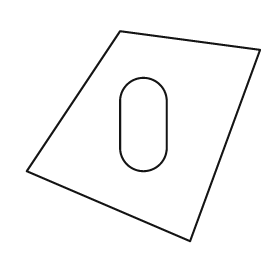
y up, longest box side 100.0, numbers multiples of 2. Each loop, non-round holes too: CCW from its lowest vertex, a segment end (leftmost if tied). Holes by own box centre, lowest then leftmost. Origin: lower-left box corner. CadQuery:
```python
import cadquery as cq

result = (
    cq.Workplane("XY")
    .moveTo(70.0, 0.0)
    .lineTo(100.0, 82.0)
    .lineTo(40.0, 90.0)
    .lineTo(0.0, 30.0)
    .close()
    .moveTo(40.0, 40.0)
    .threePointArc((50.0, 30.0), (60.0, 40.0))
    .lineTo(60.0, 60.0)
    .threePointArc((50.0, 70.0), (40.0, 60.0))
    .close()
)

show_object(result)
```